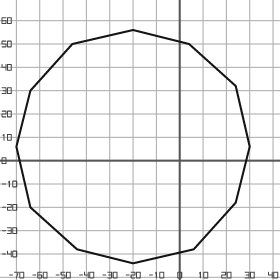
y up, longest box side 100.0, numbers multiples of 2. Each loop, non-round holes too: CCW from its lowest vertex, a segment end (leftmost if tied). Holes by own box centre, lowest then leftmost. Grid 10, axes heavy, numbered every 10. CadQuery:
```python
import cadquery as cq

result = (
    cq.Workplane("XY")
    .moveTo(-20.0, -44.0)
    .lineTo(6.0, -38.0)
    .lineTo(24.0, -18.0)
    .lineTo(30.0, 6.0)
    .lineTo(24.0, 32.0)
    .lineTo(4.0, 50.0)
    .lineTo(-20.0, 56.0)
    .lineTo(-46.0, 50.0)
    .lineTo(-64.0, 30.0)
    .lineTo(-70.0, 6.0)
    .lineTo(-64.0, -20.0)
    .lineTo(-44.0, -38.0)
    .close()
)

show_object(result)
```